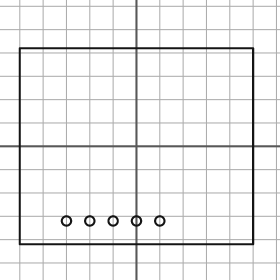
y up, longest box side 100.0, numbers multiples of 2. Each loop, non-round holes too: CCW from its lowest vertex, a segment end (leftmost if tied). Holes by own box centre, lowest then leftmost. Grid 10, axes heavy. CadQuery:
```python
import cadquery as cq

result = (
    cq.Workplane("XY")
    .moveTo(-50.0, -42.0)
    .lineTo(50.0, -42.0)
    .lineTo(50.0, 42.0)
    .lineTo(-50.0, 42.0)
    .close()
    .moveTo(-30.0, -32.0)
    .circle(2.0)
    .moveTo(-20.0, -32.0)
    .circle(2.0)
    .moveTo(-10.0, -32.0)
    .circle(2.0)
    .moveTo(0.0, -32.0)
    .circle(2.0)
    .moveTo(10.0, -32.0)
    .circle(2.0)
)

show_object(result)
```